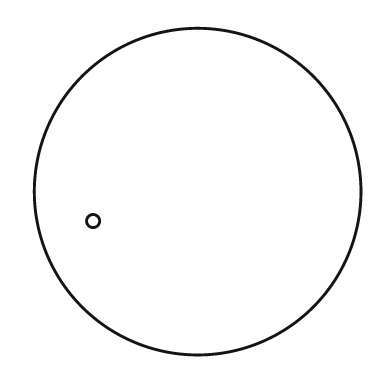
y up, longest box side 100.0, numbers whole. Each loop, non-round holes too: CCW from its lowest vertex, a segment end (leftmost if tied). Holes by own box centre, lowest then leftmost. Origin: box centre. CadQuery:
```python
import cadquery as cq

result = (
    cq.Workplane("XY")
    .moveTo(0.0, 0.0)
    .circle(50.0)
    .moveTo(-32.0, -9.0)
    .circle(2.0)
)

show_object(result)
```